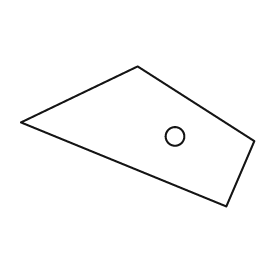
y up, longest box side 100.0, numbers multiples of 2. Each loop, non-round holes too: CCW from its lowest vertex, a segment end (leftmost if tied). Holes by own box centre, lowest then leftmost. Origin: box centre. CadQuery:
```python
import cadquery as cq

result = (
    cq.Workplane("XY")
    .moveTo(38.0, -30.0)
    .lineTo(50.0, -2.0)
    .lineTo(0.0, 30.0)
    .lineTo(-50.0, 6.0)
    .close()
    .moveTo(16.0, 0.0)
    .circle(4.0)
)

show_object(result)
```